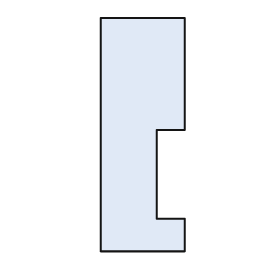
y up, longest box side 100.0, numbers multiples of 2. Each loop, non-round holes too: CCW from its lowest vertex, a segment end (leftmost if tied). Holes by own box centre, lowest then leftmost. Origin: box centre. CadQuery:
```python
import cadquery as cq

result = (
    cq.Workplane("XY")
    .moveTo(-18.0, -50.0)
    .lineTo(18.0, -50.0)
    .lineTo(18.0, -36.0)
    .lineTo(6.0, -36.0)
    .lineTo(6.0, 2.0)
    .lineTo(18.0, 2.0)
    .lineTo(18.0, 50.0)
    .lineTo(-18.0, 50.0)
    .close()
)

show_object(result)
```